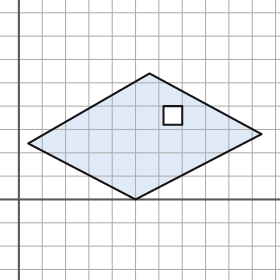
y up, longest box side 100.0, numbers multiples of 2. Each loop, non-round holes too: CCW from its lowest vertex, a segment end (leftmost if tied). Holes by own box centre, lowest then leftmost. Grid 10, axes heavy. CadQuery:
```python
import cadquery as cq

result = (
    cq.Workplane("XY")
    .moveTo(50.0, 0.0)
    .lineTo(104.0, 28.0)
    .lineTo(56.0, 54.0)
    .lineTo(4.0, 24.0)
    .close()
    .moveTo(62.0, 32.0)
    .lineTo(70.0, 32.0)
    .lineTo(70.0, 40.0)
    .lineTo(62.0, 40.0)
    .close()
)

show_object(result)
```